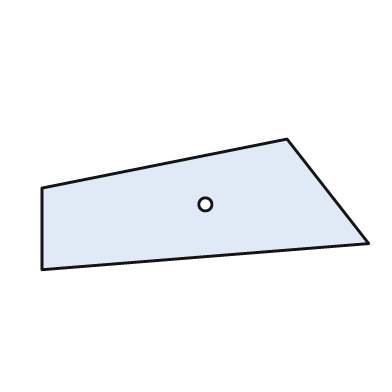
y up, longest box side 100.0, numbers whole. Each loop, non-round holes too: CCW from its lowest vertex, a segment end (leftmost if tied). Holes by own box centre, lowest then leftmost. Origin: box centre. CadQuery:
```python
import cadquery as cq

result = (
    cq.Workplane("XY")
    .moveTo(-50.0, -20.0)
    .lineTo(50.0, -12.0)
    .lineTo(25.0, 20.0)
    .lineTo(-50.0, 5.0)
    .close()
    .moveTo(0.0, 0.0)
    .circle(2.0)
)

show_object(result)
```